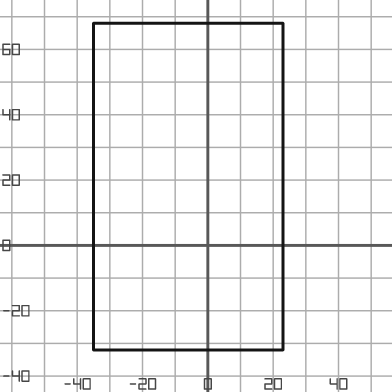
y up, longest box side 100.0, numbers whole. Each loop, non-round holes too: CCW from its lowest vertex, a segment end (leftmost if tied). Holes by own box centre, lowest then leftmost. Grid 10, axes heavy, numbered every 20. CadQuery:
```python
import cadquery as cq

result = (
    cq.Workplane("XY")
    .moveTo(-35.0, -32.0)
    .lineTo(23.0, -32.0)
    .lineTo(23.0, 68.0)
    .lineTo(-35.0, 68.0)
    .close()
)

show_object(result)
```